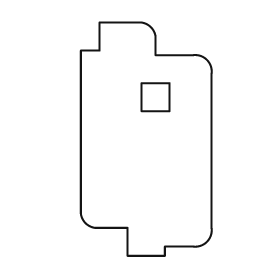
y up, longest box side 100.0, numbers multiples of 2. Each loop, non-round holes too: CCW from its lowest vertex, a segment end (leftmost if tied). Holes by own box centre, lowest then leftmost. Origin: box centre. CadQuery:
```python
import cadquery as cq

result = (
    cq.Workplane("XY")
    .moveTo(-8.0, -50.0)
    .lineTo(8.0, -50.0)
    .lineTo(8.0, -46.0)
    .lineTo(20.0, -46.0)
    .threePointArc((26.0, -44.0), (28.0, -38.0))
    .lineTo(28.0, 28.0)
    .threePointArc((26.0, 34.0), (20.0, 36.0))
    .lineTo(4.0, 36.0)
    .lineTo(4.0, 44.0)
    .threePointArc((2.0, 48.0), (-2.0, 50.0))
    .lineTo(-20.0, 50.0)
    .lineTo(-20.0, 38.0)
    .lineTo(-28.0, 38.0)
    .lineTo(-28.0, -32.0)
    .threePointArc((-26.0, -36.0), (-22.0, -38.0))
    .lineTo(-8.0, -38.0)
    .close()
    .moveTo(-2.0, 12.0)
    .lineTo(10.0, 12.0)
    .lineTo(10.0, 24.0)
    .lineTo(-2.0, 24.0)
    .close()
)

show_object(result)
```